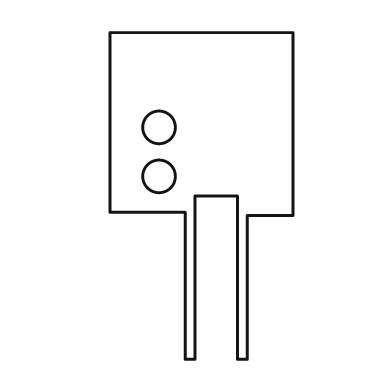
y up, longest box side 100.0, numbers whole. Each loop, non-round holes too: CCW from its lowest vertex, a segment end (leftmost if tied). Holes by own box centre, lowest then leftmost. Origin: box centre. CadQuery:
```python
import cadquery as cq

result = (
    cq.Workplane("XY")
    .moveTo(-5.0, -50.0)
    .lineTo(-2.0, -50.0)
    .lineTo(-2.0, 0.0)
    .lineTo(11.0, 0.0)
    .lineTo(11.0, -50.0)
    .lineTo(14.0, -50.0)
    .lineTo(14.0, -6.0)
    .lineTo(28.0, -6.0)
    .lineTo(28.0, 50.0)
    .lineTo(-28.0, 50.0)
    .lineTo(-28.0, -5.0)
    .lineTo(-5.0, -5.0)
    .close()
    .moveTo(-13.0, 6.0)
    .circle(5.0)
    .moveTo(-13.0, 21.0)
    .circle(5.0)
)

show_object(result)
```